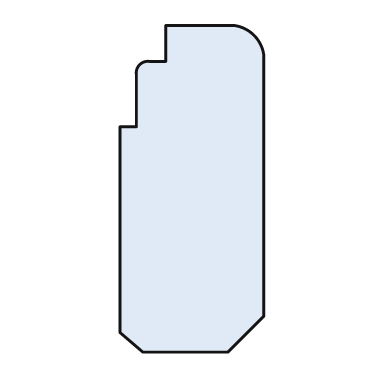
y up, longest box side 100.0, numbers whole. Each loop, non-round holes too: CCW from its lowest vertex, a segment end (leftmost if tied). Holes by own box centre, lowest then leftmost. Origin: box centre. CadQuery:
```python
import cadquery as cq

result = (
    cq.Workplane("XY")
    .moveTo(-15.0, -50.0)
    .lineTo(11.0, -50.0)
    .lineTo(22.0, -39.0)
    .lineTo(22.0, 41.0)
    .threePointArc((19.0, 47.0), (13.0, 50.0))
    .lineTo(-8.0, 50.0)
    .lineTo(-8.0, 39.0)
    .lineTo(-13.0, 39.0)
    .threePointArc((-16.0, 38.0), (-17.0, 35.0))
    .lineTo(-17.0, 19.0)
    .lineTo(-22.0, 19.0)
    .lineTo(-22.0, -44.0)
    .close()
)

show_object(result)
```